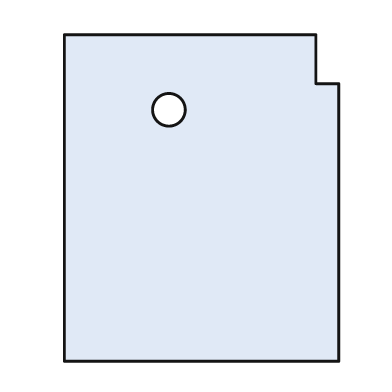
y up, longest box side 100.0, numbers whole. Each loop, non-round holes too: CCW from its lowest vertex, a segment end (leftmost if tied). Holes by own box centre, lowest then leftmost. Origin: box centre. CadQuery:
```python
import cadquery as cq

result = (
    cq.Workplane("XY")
    .moveTo(-42.0, -50.0)
    .lineTo(42.0, -50.0)
    .lineTo(42.0, 35.0)
    .lineTo(35.0, 35.0)
    .lineTo(35.0, 50.0)
    .lineTo(-42.0, 50.0)
    .close()
    .moveTo(-10.0, 27.0)
    .circle(5.0)
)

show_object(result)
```